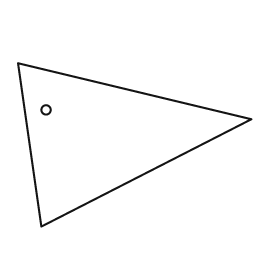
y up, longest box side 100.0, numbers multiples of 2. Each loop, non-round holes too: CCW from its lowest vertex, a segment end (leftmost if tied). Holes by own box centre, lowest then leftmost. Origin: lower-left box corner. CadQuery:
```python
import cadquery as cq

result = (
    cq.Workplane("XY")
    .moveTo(10.0, 0.0)
    .lineTo(100.0, 46.0)
    .lineTo(0.0, 70.0)
    .close()
    .moveTo(12.0, 50.0)
    .circle(2.0)
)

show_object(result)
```